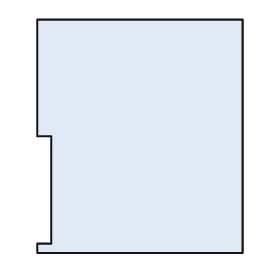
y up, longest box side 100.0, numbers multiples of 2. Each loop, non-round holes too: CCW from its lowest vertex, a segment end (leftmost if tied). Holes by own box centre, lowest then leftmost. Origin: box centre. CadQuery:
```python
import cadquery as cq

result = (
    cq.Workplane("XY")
    .moveTo(-44.0, -50.0)
    .lineTo(44.0, -50.0)
    .lineTo(44.0, 50.0)
    .lineTo(-44.0, 50.0)
    .lineTo(-44.0, 0.0)
    .lineTo(-38.0, 0.0)
    .lineTo(-38.0, -46.0)
    .lineTo(-44.0, -46.0)
    .close()
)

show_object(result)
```